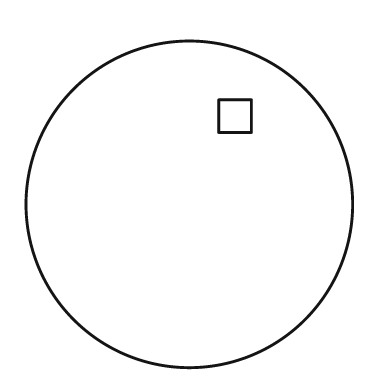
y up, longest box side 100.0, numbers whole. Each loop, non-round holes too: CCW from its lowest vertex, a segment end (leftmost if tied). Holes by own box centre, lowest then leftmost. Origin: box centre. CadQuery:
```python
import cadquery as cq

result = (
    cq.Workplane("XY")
    .moveTo(0.0, 0.0)
    .circle(50.0)
    .moveTo(9.0, 22.0)
    .lineTo(19.0, 22.0)
    .lineTo(19.0, 32.0)
    .lineTo(9.0, 32.0)
    .close()
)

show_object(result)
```